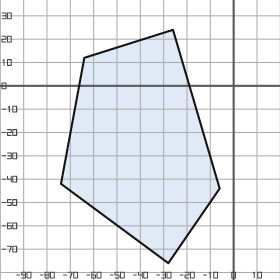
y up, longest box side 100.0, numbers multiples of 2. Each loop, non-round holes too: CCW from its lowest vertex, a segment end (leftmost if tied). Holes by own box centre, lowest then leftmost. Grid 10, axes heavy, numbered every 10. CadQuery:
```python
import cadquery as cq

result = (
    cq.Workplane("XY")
    .moveTo(-28.0, -76.0)
    .lineTo(-6.0, -44.0)
    .lineTo(-26.0, 24.0)
    .lineTo(-64.0, 12.0)
    .lineTo(-74.0, -42.0)
    .close()
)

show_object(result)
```